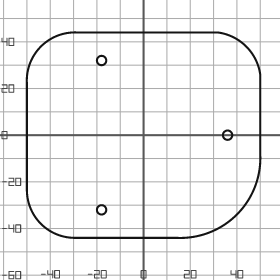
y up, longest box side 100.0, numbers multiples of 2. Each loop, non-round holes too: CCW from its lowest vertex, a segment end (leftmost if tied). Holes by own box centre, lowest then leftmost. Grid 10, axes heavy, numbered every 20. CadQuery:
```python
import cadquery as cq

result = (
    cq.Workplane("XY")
    .moveTo(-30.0, -44.0)
    .lineTo(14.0, -44.0)
    .threePointArc((40.0, -34.0), (50.0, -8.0))
    .lineTo(50.0, 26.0)
    .threePointArc((44.0, 38.0), (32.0, 44.0))
    .lineTo(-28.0, 44.0)
    .threePointArc((-44.0, 38.0), (-50.0, 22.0))
    .lineTo(-50.0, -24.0)
    .threePointArc((-44.0, -38.0), (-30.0, -44.0))
    .close()
    .moveTo(-18.0, -32.0)
    .circle(2.0)
    .moveTo(36.0, 0.0)
    .circle(2.0)
    .moveTo(-18.0, 32.0)
    .circle(2.0)
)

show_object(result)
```